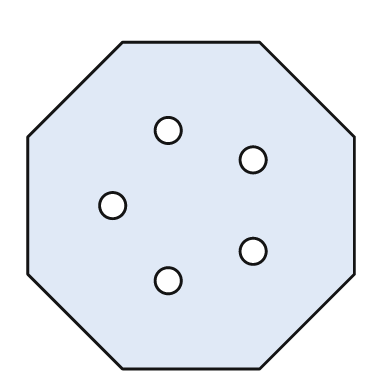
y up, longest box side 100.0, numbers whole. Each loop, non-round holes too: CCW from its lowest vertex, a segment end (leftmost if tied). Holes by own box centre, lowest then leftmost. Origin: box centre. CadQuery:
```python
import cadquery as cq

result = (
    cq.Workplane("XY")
    .moveTo(-21.0, -50.0)
    .lineTo(21.0, -50.0)
    .lineTo(50.0, -21.0)
    .lineTo(50.0, 21.0)
    .lineTo(21.0, 50.0)
    .lineTo(-21.0, 50.0)
    .lineTo(-50.0, 21.0)
    .lineTo(-50.0, -21.0)
    .close()
    .moveTo(-7.0, -23.0)
    .circle(4.0)
    .moveTo(19.0, -14.0)
    .circle(4.0)
    .moveTo(-24.0, 0.0)
    .circle(4.0)
    .moveTo(19.0, 14.0)
    .circle(4.0)
    .moveTo(-7.0, 23.0)
    .circle(4.0)
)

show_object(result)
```